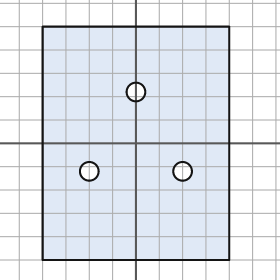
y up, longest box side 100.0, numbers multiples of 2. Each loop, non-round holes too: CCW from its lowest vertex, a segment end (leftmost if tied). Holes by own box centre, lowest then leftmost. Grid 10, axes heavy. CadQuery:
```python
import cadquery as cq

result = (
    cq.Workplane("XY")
    .moveTo(-40.0, -50.0)
    .lineTo(40.0, -50.0)
    .lineTo(40.0, 50.0)
    .lineTo(-40.0, 50.0)
    .close()
    .moveTo(-20.0, -12.0)
    .circle(4.0)
    .moveTo(20.0, -12.0)
    .circle(4.0)
    .moveTo(0.0, 22.0)
    .circle(4.0)
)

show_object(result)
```